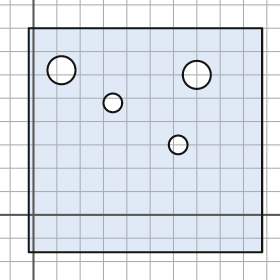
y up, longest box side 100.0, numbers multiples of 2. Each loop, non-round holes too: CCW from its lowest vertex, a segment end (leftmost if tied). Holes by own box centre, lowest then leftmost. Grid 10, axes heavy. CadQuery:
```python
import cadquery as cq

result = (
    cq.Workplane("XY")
    .moveTo(-2.0, -16.0)
    .lineTo(98.0, -16.0)
    .lineTo(98.0, 80.0)
    .lineTo(-2.0, 80.0)
    .close()
    .moveTo(62.0, 30.0)
    .circle(4.0)
    .moveTo(34.0, 48.0)
    .circle(4.0)
    .moveTo(70.0, 60.0)
    .circle(6.0)
    .moveTo(12.0, 62.0)
    .circle(6.0)
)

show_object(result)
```